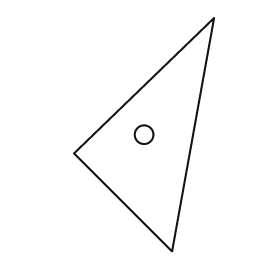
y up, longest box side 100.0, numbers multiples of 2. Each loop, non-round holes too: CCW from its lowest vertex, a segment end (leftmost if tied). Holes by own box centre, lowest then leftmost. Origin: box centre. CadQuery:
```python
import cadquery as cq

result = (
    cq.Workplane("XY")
    .moveTo(12.0, -50.0)
    .lineTo(30.0, 50.0)
    .lineTo(-30.0, -8.0)
    .close()
    .moveTo(0.0, 0.0)
    .circle(4.0)
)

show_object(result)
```